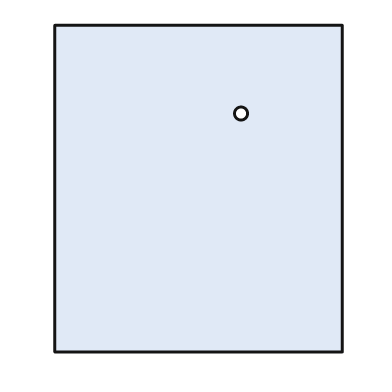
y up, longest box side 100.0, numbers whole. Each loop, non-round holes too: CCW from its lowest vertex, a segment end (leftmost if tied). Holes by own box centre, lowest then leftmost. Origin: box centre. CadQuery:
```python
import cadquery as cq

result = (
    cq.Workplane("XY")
    .moveTo(-44.0, -50.0)
    .lineTo(44.0, -50.0)
    .lineTo(44.0, 50.0)
    .lineTo(-44.0, 50.0)
    .close()
    .moveTo(13.0, 23.0)
    .circle(2.0)
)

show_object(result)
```